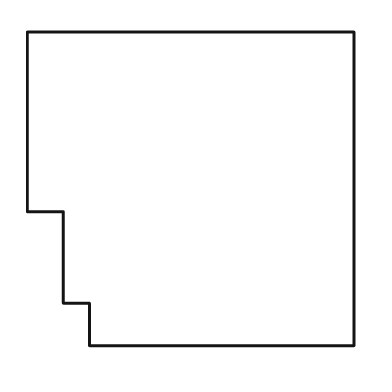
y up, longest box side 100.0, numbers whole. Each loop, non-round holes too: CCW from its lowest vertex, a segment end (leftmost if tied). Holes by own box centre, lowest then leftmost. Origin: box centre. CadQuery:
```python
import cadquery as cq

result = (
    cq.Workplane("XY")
    .moveTo(-31.0, -48.0)
    .lineTo(50.0, -48.0)
    .lineTo(50.0, 48.0)
    .lineTo(-50.0, 48.0)
    .lineTo(-50.0, -7.0)
    .lineTo(-39.0, -7.0)
    .lineTo(-39.0, -35.0)
    .lineTo(-31.0, -35.0)
    .close()
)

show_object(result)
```